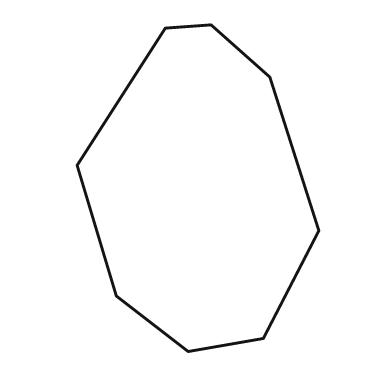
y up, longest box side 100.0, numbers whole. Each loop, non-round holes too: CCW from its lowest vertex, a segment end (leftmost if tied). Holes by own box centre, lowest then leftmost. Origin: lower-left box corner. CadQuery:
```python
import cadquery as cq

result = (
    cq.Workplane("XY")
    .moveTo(34.0, 0.0)
    .lineTo(57.0, 4.0)
    .lineTo(74.0, 37.0)
    .lineTo(59.0, 84.0)
    .lineTo(41.0, 100.0)
    .lineTo(27.0, 99.0)
    .lineTo(0.0, 57.0)
    .lineTo(12.0, 17.0)
    .close()
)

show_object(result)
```